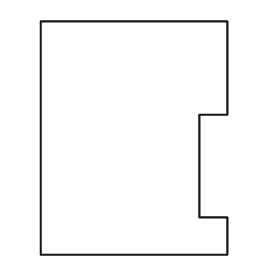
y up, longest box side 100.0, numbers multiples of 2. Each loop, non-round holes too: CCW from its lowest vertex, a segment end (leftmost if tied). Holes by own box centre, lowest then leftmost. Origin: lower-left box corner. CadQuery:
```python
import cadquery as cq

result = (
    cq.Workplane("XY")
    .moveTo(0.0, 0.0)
    .lineTo(80.0, 0.0)
    .lineTo(80.0, 16.0)
    .lineTo(68.0, 16.0)
    .lineTo(68.0, 60.0)
    .lineTo(80.0, 60.0)
    .lineTo(80.0, 100.0)
    .lineTo(0.0, 100.0)
    .close()
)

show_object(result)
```